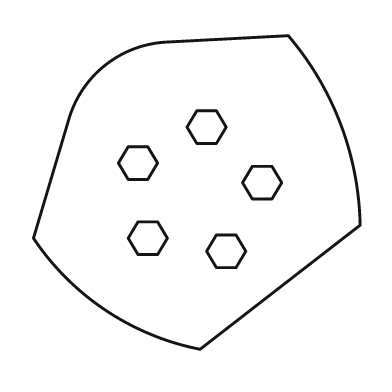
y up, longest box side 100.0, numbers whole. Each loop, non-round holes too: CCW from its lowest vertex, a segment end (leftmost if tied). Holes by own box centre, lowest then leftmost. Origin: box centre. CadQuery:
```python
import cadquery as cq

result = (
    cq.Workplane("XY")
    .moveTo(1.0, -48.0)
    .lineTo(50.0, -10.0)
    .threePointArc((44.0, 21.0), (28.0, 48.0))
    .lineTo(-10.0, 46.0)
    .threePointArc((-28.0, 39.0), (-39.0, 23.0))
    .lineTo(-50.0, -14.0)
    .threePointArc((-28.0, -36.0), (1.0, -48.0))
    .close()
    .moveTo(6.0, -23.0)
    .lineTo(12.0, -23.0)
    .lineTo(15.0, -18.0)
    .lineTo(12.0, -13.0)
    .lineTo(6.0, -13.0)
    .lineTo(3.0, -18.0)
    .close()
    .moveTo(-18.0, -19.0)
    .lineTo(-12.0, -19.0)
    .lineTo(-9.0, -14.0)
    .lineTo(-12.0, -9.0)
    .lineTo(-18.0, -9.0)
    .lineTo(-21.0, -14.0)
    .close()
    .moveTo(17.0, -2.0)
    .lineTo(23.0, -2.0)
    .lineTo(26.0, 3.0)
    .lineTo(23.0, 8.0)
    .lineTo(17.0, 8.0)
    .lineTo(14.0, 3.0)
    .close()
    .moveTo(-21.0, 4.0)
    .lineTo(-15.0, 4.0)
    .lineTo(-12.0, 9.0)
    .lineTo(-15.0, 14.0)
    .lineTo(-21.0, 14.0)
    .lineTo(-24.0, 9.0)
    .close()
    .moveTo(0.0, 15.0)
    .lineTo(6.0, 15.0)
    .lineTo(9.0, 20.0)
    .lineTo(6.0, 25.0)
    .lineTo(0.0, 25.0)
    .lineTo(-3.0, 20.0)
    .close()
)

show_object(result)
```